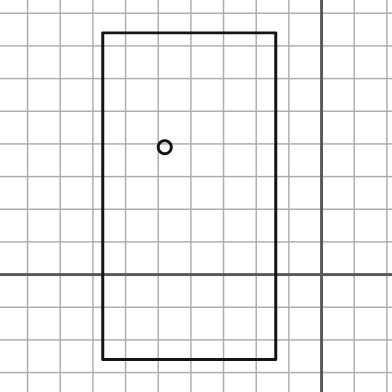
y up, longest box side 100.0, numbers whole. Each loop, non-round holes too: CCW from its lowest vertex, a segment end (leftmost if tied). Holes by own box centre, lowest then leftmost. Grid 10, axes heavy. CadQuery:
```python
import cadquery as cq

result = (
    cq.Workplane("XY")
    .moveTo(-67.0, -26.0)
    .lineTo(-14.0, -26.0)
    .lineTo(-14.0, 74.0)
    .lineTo(-67.0, 74.0)
    .close()
    .moveTo(-48.0, 39.0)
    .circle(2.0)
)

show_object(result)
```